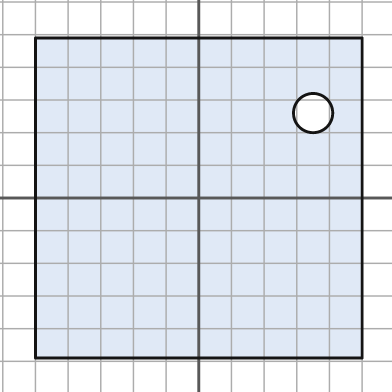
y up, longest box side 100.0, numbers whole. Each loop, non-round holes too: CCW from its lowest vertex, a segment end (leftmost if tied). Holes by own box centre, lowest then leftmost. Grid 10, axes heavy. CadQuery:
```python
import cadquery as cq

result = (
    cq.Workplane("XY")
    .moveTo(-50.0, -49.0)
    .lineTo(50.0, -49.0)
    .lineTo(50.0, 49.0)
    .lineTo(-50.0, 49.0)
    .close()
    .moveTo(35.0, 26.0)
    .circle(6.0)
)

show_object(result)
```